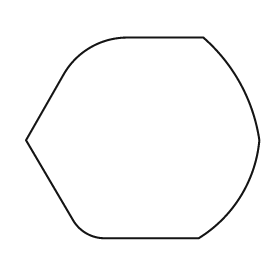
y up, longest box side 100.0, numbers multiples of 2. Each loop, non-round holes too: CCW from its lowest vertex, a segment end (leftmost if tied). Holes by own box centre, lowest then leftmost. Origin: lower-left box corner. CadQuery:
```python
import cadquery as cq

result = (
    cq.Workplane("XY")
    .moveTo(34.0, 0.0)
    .lineTo(74.0, 0.0)
    .threePointArc((92.0, 18.0), (100.0, 42.0))
    .threePointArc((92.0, 66.0), (76.0, 86.0))
    .lineTo(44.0, 86.0)
    .threePointArc((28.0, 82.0), (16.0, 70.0))
    .lineTo(0.0, 42.0)
    .lineTo(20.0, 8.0)
    .threePointArc((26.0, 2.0), (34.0, 0.0))
    .close()
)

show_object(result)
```